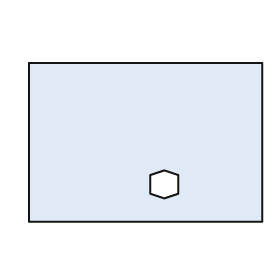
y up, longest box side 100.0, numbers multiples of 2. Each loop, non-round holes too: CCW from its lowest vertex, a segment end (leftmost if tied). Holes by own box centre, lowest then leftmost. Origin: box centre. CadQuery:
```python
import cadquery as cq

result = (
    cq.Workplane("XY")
    .moveTo(-50.0, -34.0)
    .lineTo(50.0, -34.0)
    .lineTo(50.0, 34.0)
    .lineTo(-50.0, 34.0)
    .close()
    .moveTo(8.0, -24.0)
    .lineTo(14.0, -22.0)
    .lineTo(14.0, -14.0)
    .lineTo(8.0, -12.0)
    .lineTo(2.0, -14.0)
    .lineTo(2.0, -22.0)
    .close()
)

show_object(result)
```